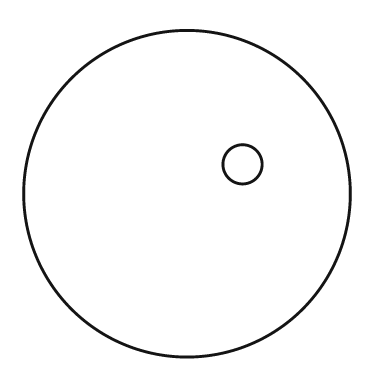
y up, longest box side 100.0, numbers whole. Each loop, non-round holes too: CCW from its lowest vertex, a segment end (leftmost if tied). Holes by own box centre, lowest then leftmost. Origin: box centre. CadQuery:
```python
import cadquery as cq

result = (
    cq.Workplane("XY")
    .moveTo(0.0, 0.0)
    .circle(50.0)
    .moveTo(17.0, 9.0)
    .circle(6.0)
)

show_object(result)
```